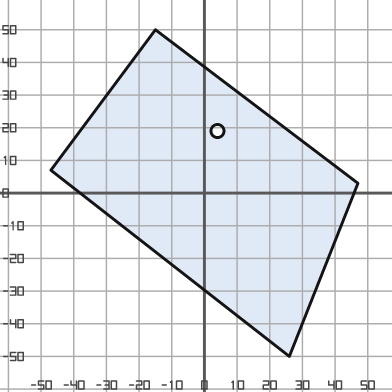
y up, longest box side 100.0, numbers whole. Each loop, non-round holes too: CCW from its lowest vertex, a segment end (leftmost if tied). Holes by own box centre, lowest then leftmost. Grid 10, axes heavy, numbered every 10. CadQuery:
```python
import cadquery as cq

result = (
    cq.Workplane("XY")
    .moveTo(26.0, -50.0)
    .lineTo(47.0, 3.0)
    .lineTo(-15.0, 50.0)
    .lineTo(-47.0, 7.0)
    .close()
    .moveTo(4.0, 19.0)
    .circle(2.0)
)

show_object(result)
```